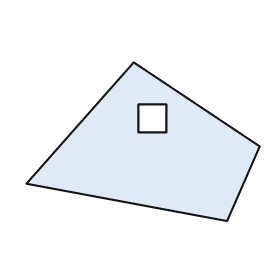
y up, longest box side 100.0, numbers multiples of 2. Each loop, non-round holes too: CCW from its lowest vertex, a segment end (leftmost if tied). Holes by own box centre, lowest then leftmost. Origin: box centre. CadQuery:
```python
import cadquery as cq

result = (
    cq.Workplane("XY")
    .moveTo(36.0, -34.0)
    .lineTo(50.0, -2.0)
    .lineTo(-4.0, 34.0)
    .lineTo(-50.0, -18.0)
    .close()
    .moveTo(-2.0, 4.0)
    .lineTo(10.0, 4.0)
    .lineTo(10.0, 16.0)
    .lineTo(-2.0, 16.0)
    .close()
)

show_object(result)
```